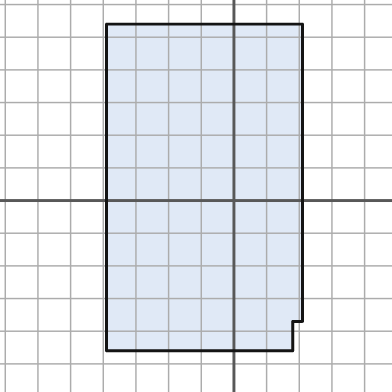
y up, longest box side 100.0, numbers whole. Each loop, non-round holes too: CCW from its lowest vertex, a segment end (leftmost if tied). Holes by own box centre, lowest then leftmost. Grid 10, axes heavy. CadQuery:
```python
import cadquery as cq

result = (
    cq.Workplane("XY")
    .moveTo(-39.0, -46.0)
    .lineTo(18.0, -46.0)
    .lineTo(18.0, -37.0)
    .lineTo(21.0, -37.0)
    .lineTo(21.0, 54.0)
    .lineTo(-39.0, 54.0)
    .close()
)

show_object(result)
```